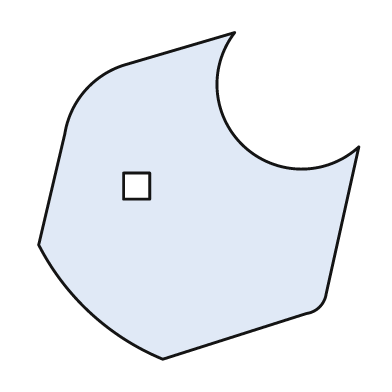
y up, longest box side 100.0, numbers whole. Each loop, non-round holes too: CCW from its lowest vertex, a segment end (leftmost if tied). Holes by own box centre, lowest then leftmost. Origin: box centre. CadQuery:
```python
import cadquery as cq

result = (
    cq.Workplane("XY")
    .moveTo(-11.0, -50.0)
    .lineTo(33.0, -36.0)
    .threePointArc((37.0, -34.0), (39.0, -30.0))
    .lineTo(49.0, 15.0)
    .threePointArc((14.0, 15.0), (11.0, 50.0))
    .lineTo(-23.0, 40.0)
    .threePointArc((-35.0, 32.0), (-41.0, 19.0))
    .lineTo(-49.0, -15.0)
    .threePointArc((-33.0, -36.0), (-11.0, -50.0))
    .close()
    .moveTo(-23.0, -1.0)
    .lineTo(-15.0, -1.0)
    .lineTo(-15.0, 7.0)
    .lineTo(-23.0, 7.0)
    .close()
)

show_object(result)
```